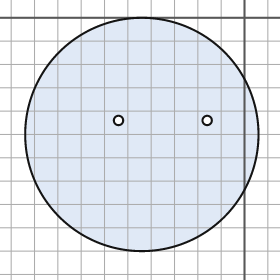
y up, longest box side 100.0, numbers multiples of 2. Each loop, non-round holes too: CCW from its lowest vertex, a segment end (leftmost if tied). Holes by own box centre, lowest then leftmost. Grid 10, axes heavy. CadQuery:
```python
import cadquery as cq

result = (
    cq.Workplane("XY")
    .moveTo(-44.0, -50.0)
    .circle(50.0)
    .moveTo(-54.0, -44.0)
    .circle(2.0)
    .moveTo(-16.0, -44.0)
    .circle(2.0)
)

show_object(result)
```